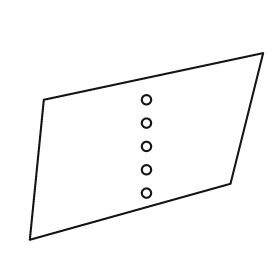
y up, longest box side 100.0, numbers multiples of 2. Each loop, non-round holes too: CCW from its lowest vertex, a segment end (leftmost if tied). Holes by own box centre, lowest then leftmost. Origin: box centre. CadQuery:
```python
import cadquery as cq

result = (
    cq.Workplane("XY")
    .moveTo(-50.0, -40.0)
    .lineTo(36.0, -16.0)
    .lineTo(50.0, 40.0)
    .lineTo(-44.0, 20.0)
    .close()
    .moveTo(0.0, -20.0)
    .circle(2.0)
    .moveTo(0.0, -10.0)
    .circle(2.0)
    .moveTo(0.0, 0.0)
    .circle(2.0)
    .moveTo(0.0, 10.0)
    .circle(2.0)
    .moveTo(0.0, 20.0)
    .circle(2.0)
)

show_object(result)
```